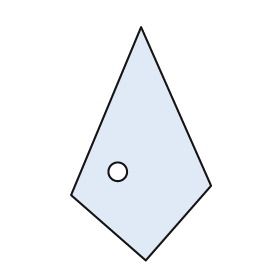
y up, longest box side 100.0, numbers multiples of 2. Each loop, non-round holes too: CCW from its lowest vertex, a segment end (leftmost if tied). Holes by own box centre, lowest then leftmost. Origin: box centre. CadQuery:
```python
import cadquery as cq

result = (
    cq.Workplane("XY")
    .moveTo(2.0, -50.0)
    .lineTo(30.0, -18.0)
    .lineTo(0.0, 50.0)
    .lineTo(-30.0, -22.0)
    .close()
    .moveTo(-10.0, -12.0)
    .circle(4.0)
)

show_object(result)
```